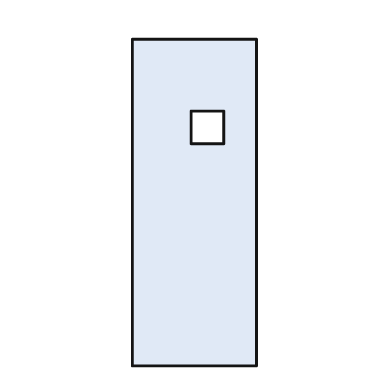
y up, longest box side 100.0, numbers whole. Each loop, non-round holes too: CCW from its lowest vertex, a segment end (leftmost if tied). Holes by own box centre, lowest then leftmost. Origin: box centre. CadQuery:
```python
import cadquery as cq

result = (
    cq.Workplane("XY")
    .moveTo(-19.0, -50.0)
    .lineTo(19.0, -50.0)
    .lineTo(19.0, 50.0)
    .lineTo(-19.0, 50.0)
    .close()
    .moveTo(-1.0, 18.0)
    .lineTo(9.0, 18.0)
    .lineTo(9.0, 28.0)
    .lineTo(-1.0, 28.0)
    .close()
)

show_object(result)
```